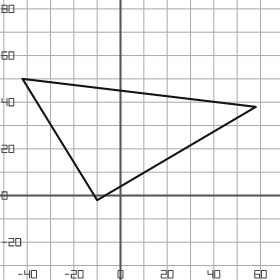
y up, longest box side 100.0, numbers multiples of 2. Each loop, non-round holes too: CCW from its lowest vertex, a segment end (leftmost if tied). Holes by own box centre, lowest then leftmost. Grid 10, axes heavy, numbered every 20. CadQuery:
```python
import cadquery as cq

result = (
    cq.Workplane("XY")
    .moveTo(-10.0, -2.0)
    .lineTo(58.0, 38.0)
    .lineTo(-42.0, 50.0)
    .close()
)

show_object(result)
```